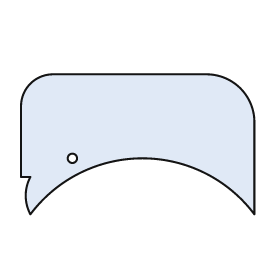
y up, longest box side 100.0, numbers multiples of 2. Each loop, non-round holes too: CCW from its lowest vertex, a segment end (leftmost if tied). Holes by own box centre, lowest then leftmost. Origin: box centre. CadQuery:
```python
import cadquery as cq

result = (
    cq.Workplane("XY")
    .moveTo(-46.0, -30.0)
    .threePointArc((2.0, -6.0), (50.0, -30.0))
    .lineTo(50.0, 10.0)
    .threePointArc((44.0, 24.0), (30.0, 30.0))
    .lineTo(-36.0, 30.0)
    .threePointArc((-46.0, 26.0), (-50.0, 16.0))
    .lineTo(-50.0, -14.0)
    .lineTo(-46.0, -14.0)
    .threePointArc((-48.0, -22.0), (-46.0, -30.0))
    .close()
    .moveTo(-28.0, -6.0)
    .circle(2.0)
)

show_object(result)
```